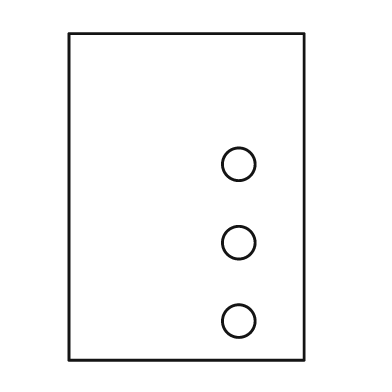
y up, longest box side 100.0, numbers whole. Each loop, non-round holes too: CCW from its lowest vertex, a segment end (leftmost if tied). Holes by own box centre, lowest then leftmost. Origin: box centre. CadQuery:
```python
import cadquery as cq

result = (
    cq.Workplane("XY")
    .moveTo(-36.0, -50.0)
    .lineTo(36.0, -50.0)
    .lineTo(36.0, 50.0)
    .lineTo(-36.0, 50.0)
    .close()
    .moveTo(16.0, -38.0)
    .circle(5.0)
    .moveTo(16.0, -14.0)
    .circle(5.0)
    .moveTo(16.0, 10.0)
    .circle(5.0)
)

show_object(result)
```